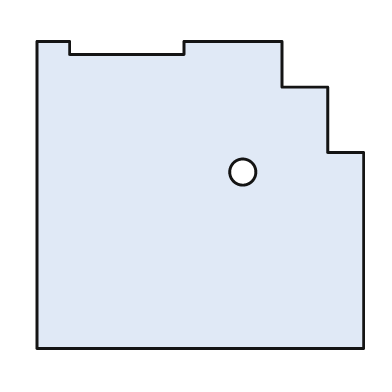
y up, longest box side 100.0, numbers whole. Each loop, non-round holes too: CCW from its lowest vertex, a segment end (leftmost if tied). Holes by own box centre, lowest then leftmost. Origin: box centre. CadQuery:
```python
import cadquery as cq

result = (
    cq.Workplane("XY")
    .moveTo(-50.0, -47.0)
    .lineTo(50.0, -47.0)
    .lineTo(50.0, 13.0)
    .lineTo(39.0, 13.0)
    .lineTo(39.0, 33.0)
    .lineTo(25.0, 33.0)
    .lineTo(25.0, 47.0)
    .lineTo(-5.0, 47.0)
    .lineTo(-5.0, 43.0)
    .lineTo(-40.0, 43.0)
    .lineTo(-40.0, 47.0)
    .lineTo(-50.0, 47.0)
    .close()
    .moveTo(13.0, 7.0)
    .circle(4.0)
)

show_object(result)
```